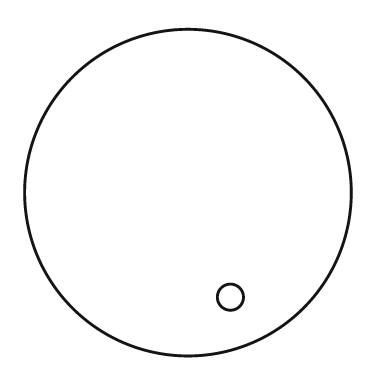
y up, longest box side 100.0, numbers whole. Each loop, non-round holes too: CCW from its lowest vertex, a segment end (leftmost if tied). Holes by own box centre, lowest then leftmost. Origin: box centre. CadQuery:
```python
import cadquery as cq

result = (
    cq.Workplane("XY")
    .moveTo(0.0, 0.0)
    .circle(50.0)
    .moveTo(13.0, -32.0)
    .circle(4.0)
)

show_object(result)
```